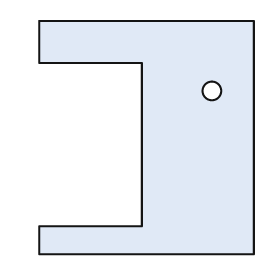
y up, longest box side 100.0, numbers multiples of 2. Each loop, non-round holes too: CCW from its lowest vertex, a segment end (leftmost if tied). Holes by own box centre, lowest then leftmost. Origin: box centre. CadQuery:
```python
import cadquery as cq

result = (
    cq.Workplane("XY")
    .moveTo(-46.0, -50.0)
    .lineTo(46.0, -50.0)
    .lineTo(46.0, 50.0)
    .lineTo(-46.0, 50.0)
    .lineTo(-46.0, 32.0)
    .lineTo(-2.0, 32.0)
    .lineTo(-2.0, -38.0)
    .lineTo(-46.0, -38.0)
    .close()
    .moveTo(28.0, 20.0)
    .circle(4.0)
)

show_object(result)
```